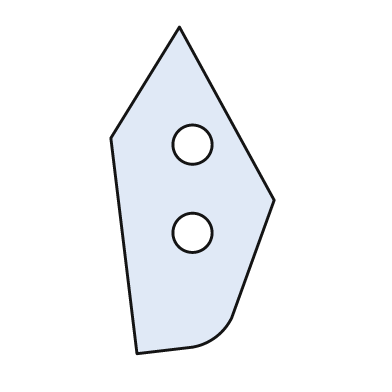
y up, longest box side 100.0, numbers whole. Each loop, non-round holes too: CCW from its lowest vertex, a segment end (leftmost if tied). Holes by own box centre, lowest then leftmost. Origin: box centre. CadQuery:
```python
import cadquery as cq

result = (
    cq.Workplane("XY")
    .moveTo(-17.0, -50.0)
    .lineTo(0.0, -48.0)
    .threePointArc((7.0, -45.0), (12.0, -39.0))
    .lineTo(25.0, -3.0)
    .lineTo(-4.0, 50.0)
    .lineTo(-25.0, 16.0)
    .close()
    .moveTo(0.0, -13.0)
    .circle(6.0)
    .moveTo(0.0, 14.0)
    .circle(6.0)
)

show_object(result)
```